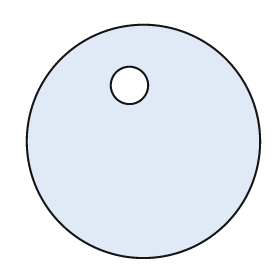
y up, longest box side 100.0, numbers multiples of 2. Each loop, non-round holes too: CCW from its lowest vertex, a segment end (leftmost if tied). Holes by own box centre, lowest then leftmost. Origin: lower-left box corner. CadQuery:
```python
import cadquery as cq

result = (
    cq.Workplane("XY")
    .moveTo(50.0, 50.0)
    .circle(50.0)
    .moveTo(44.0, 74.0)
    .circle(8.0)
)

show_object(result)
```